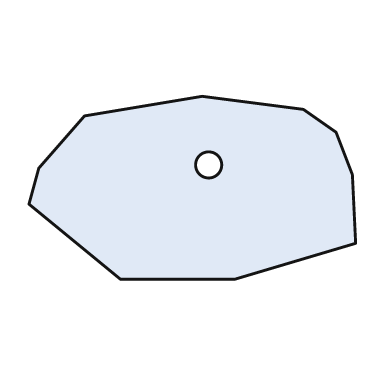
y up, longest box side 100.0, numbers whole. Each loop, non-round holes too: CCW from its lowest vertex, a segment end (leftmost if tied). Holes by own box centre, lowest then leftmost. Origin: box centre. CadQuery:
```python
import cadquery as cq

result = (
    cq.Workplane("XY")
    .moveTo(-22.0, -28.0)
    .lineTo(13.0, -28.0)
    .lineTo(50.0, -17.0)
    .lineTo(49.0, 4.0)
    .lineTo(44.0, 17.0)
    .lineTo(34.0, 24.0)
    .lineTo(3.0, 28.0)
    .lineTo(-33.0, 22.0)
    .lineTo(-47.0, 6.0)
    .lineTo(-50.0, -5.0)
    .close()
    .moveTo(5.0, 7.0)
    .circle(4.0)
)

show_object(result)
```